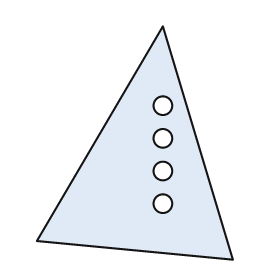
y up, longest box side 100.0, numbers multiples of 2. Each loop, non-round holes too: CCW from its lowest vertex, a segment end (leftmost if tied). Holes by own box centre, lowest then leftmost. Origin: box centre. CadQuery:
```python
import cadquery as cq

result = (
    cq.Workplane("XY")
    .moveTo(42.0, -50.0)
    .lineTo(12.0, 50.0)
    .lineTo(-42.0, -42.0)
    .close()
    .moveTo(12.0, -26.0)
    .circle(4.0)
    .moveTo(12.0, -12.0)
    .circle(4.0)
    .moveTo(12.0, 2.0)
    .circle(4.0)
    .moveTo(12.0, 16.0)
    .circle(4.0)
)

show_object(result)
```